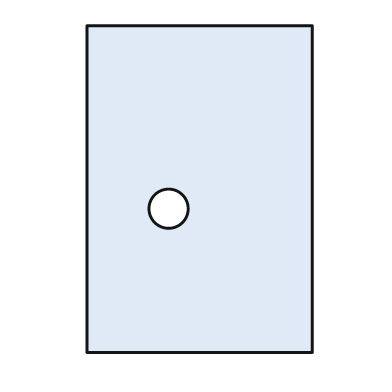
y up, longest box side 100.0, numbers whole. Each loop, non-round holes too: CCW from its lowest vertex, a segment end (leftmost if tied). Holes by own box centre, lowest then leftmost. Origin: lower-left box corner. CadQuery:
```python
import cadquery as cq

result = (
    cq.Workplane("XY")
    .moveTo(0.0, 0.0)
    .lineTo(69.0, 0.0)
    .lineTo(69.0, 100.0)
    .lineTo(0.0, 100.0)
    .close()
    .moveTo(25.0, 44.0)
    .circle(6.0)
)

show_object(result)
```